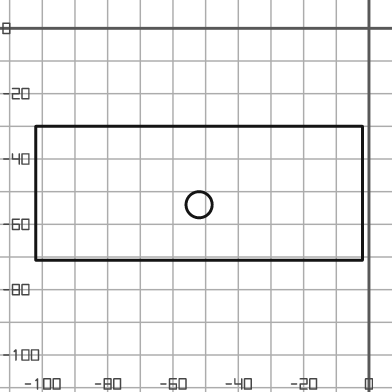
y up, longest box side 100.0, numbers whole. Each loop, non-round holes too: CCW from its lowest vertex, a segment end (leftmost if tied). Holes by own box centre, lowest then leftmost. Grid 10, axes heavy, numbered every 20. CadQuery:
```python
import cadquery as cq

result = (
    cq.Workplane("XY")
    .moveTo(-102.0, -71.0)
    .lineTo(-2.0, -71.0)
    .lineTo(-2.0, -30.0)
    .lineTo(-102.0, -30.0)
    .close()
    .moveTo(-52.0, -54.0)
    .circle(4.0)
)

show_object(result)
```